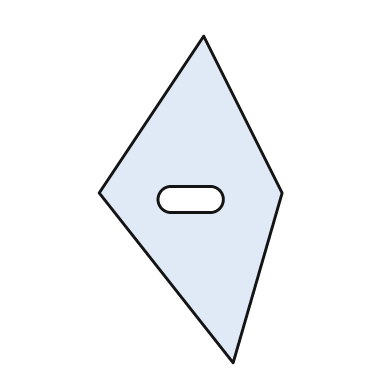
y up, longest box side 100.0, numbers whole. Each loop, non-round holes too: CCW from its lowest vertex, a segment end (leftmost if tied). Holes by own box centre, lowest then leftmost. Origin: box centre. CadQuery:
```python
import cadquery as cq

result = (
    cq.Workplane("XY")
    .moveTo(13.0, -50.0)
    .lineTo(28.0, 2.0)
    .lineTo(4.0, 50.0)
    .lineTo(-28.0, 2.0)
    .close()
    .moveTo(-6.0, -4.0)
    .lineTo(6.0, -4.0)
    .threePointArc((10.0, 0.0), (6.0, 4.0))
    .lineTo(-6.0, 4.0)
    .threePointArc((-10.0, 0.0), (-6.0, -4.0))
    .close()
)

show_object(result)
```